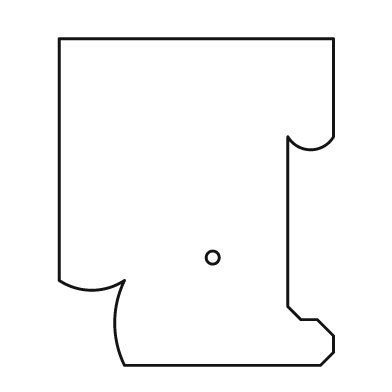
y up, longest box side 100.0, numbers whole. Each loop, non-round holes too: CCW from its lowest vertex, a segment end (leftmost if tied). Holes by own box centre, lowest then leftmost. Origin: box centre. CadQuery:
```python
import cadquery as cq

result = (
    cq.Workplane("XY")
    .moveTo(-22.0, -50.0)
    .lineTo(38.0, -50.0)
    .lineTo(42.0, -46.0)
    .lineTo(42.0, -41.0)
    .lineTo(37.0, -36.0)
    .lineTo(32.0, -36.0)
    .lineTo(28.0, -32.0)
    .lineTo(28.0, 20.0)
    .threePointArc((35.0, 16.0), (42.0, 20.0))
    .lineTo(42.0, 50.0)
    .lineTo(-42.0, 50.0)
    .lineTo(-42.0, -24.0)
    .threePointArc((-32.0, -27.0), (-22.0, -24.0))
    .threePointArc((-25.0, -37.0), (-22.0, -50.0))
    .close()
    .moveTo(5.0, -17.0)
    .circle(2.0)
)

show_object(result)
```